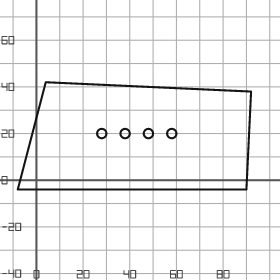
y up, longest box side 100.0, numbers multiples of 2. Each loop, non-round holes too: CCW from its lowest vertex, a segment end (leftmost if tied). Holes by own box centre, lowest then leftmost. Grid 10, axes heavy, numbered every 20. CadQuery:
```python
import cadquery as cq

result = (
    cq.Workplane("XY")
    .moveTo(-8.0, -4.0)
    .lineTo(90.0, -4.0)
    .lineTo(92.0, 38.0)
    .lineTo(4.0, 42.0)
    .close()
    .moveTo(28.0, 20.0)
    .circle(2.0)
    .moveTo(38.0, 20.0)
    .circle(2.0)
    .moveTo(48.0, 20.0)
    .circle(2.0)
    .moveTo(58.0, 20.0)
    .circle(2.0)
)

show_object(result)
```